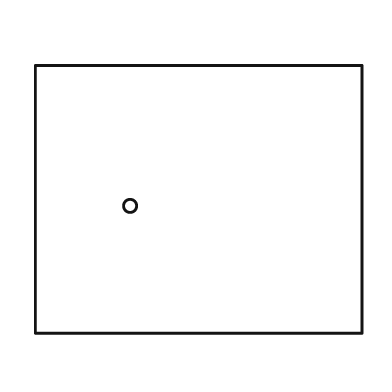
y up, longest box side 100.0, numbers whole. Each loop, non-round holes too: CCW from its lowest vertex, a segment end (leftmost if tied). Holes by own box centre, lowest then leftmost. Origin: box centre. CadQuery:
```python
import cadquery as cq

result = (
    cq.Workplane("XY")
    .moveTo(-50.0, -41.0)
    .lineTo(50.0, -41.0)
    .lineTo(50.0, 41.0)
    .lineTo(-50.0, 41.0)
    .close()
    .moveTo(-21.0, -2.0)
    .circle(2.0)
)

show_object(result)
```